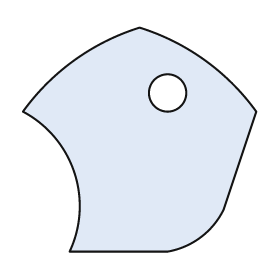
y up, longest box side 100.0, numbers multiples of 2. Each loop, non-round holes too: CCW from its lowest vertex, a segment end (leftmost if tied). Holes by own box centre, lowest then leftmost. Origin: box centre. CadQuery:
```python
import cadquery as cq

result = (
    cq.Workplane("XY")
    .moveTo(-30.0, -48.0)
    .lineTo(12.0, -48.0)
    .threePointArc((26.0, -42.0), (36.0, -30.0))
    .lineTo(50.0, 12.0)
    .threePointArc((28.0, 34.0), (0.0, 48.0))
    .threePointArc((-28.0, 34.0), (-50.0, 12.0))
    .threePointArc((-28.0, -14.0), (-30.0, -48.0))
    .close()
    .moveTo(12.0, 20.0)
    .circle(8.0)
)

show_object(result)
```